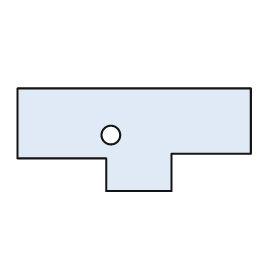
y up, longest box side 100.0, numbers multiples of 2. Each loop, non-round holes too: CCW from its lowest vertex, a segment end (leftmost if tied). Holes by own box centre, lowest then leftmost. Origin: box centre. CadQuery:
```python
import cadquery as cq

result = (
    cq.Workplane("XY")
    .moveTo(-12.0, -22.0)
    .lineTo(16.0, -22.0)
    .lineTo(16.0, -6.0)
    .lineTo(50.0, -6.0)
    .lineTo(50.0, 22.0)
    .lineTo(-50.0, 22.0)
    .lineTo(-50.0, -8.0)
    .lineTo(-12.0, -8.0)
    .close()
    .moveTo(-10.0, 2.0)
    .circle(4.0)
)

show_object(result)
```